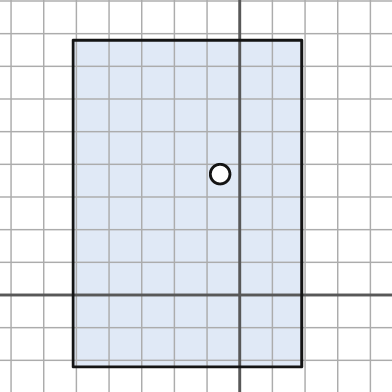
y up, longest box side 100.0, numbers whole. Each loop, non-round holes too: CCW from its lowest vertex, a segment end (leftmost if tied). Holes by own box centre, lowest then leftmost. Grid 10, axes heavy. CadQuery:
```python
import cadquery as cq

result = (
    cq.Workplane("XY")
    .moveTo(-51.0, -22.0)
    .lineTo(19.0, -22.0)
    .lineTo(19.0, 78.0)
    .lineTo(-51.0, 78.0)
    .close()
    .moveTo(-6.0, 37.0)
    .circle(3.0)
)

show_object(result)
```